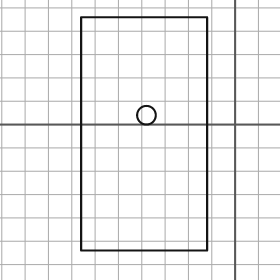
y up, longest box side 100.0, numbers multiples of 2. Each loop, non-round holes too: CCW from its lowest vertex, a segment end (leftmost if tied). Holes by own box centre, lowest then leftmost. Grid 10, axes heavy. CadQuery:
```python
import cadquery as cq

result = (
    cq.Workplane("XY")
    .moveTo(-66.0, -54.0)
    .lineTo(-12.0, -54.0)
    .lineTo(-12.0, 46.0)
    .lineTo(-66.0, 46.0)
    .close()
    .moveTo(-38.0, 4.0)
    .circle(4.0)
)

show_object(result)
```